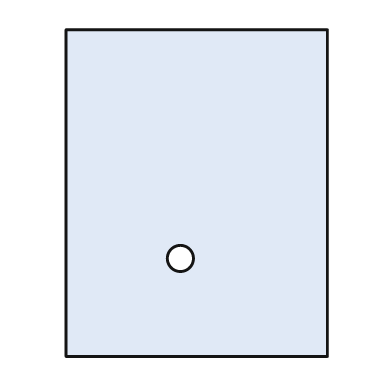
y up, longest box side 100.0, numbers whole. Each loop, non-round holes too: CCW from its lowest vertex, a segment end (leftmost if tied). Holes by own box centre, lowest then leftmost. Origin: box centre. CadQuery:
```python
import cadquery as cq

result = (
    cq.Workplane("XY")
    .moveTo(-40.0, -50.0)
    .lineTo(40.0, -50.0)
    .lineTo(40.0, 50.0)
    .lineTo(-40.0, 50.0)
    .close()
    .moveTo(-5.0, -20.0)
    .circle(4.0)
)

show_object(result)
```